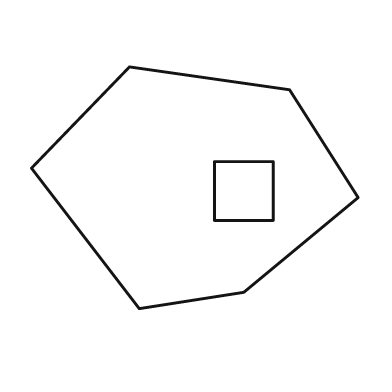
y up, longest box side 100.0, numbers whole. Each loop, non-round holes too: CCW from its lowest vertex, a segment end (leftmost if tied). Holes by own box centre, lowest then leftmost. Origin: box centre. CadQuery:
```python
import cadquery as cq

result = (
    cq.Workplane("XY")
    .moveTo(-17.0, -37.0)
    .lineTo(15.0, -32.0)
    .lineTo(50.0, -3.0)
    .lineTo(29.0, 30.0)
    .lineTo(-20.0, 37.0)
    .lineTo(-50.0, 6.0)
    .close()
    .moveTo(6.0, -10.0)
    .lineTo(24.0, -10.0)
    .lineTo(24.0, 8.0)
    .lineTo(6.0, 8.0)
    .close()
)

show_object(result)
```